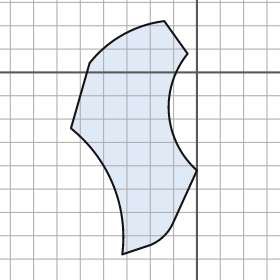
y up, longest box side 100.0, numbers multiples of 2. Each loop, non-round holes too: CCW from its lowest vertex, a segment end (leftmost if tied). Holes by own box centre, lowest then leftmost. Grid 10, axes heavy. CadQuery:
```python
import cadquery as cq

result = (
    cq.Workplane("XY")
    .moveTo(-32.0, -78.0)
    .lineTo(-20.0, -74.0)
    .threePointArc((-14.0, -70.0), (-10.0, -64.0))
    .lineTo(0.0, -42.0)
    .threePointArc((-12.0, -18.0), (-4.0, 8.0))
    .lineTo(-14.0, 22.0)
    .threePointArc((-32.0, 16.0), (-46.0, 4.0))
    .lineTo(-54.0, -24.0)
    .threePointArc((-36.0, -48.0), (-32.0, -78.0))
    .close()
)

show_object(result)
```